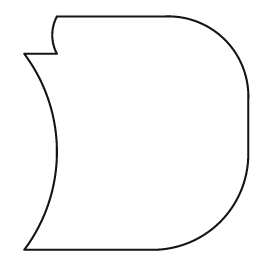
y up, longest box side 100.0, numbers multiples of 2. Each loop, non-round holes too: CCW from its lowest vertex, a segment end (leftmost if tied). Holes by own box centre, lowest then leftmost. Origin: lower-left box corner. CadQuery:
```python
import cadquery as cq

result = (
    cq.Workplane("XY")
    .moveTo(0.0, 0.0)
    .lineTo(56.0, 0.0)
    .threePointArc((84.0, 12.0), (96.0, 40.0))
    .lineTo(96.0, 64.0)
    .threePointArc((86.0, 90.0), (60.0, 100.0))
    .lineTo(14.0, 100.0)
    .threePointArc((12.0, 92.0), (14.0, 84.0))
    .lineTo(0.0, 84.0)
    .threePointArc((14.0, 42.0), (0.0, 0.0))
    .close()
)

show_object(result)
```